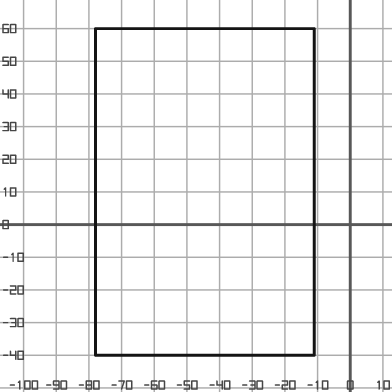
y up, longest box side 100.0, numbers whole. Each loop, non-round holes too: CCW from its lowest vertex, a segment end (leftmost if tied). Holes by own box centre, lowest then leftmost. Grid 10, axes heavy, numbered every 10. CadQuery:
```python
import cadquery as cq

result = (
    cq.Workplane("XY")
    .moveTo(-78.0, -40.0)
    .lineTo(-11.0, -40.0)
    .lineTo(-11.0, 60.0)
    .lineTo(-78.0, 60.0)
    .close()
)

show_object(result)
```